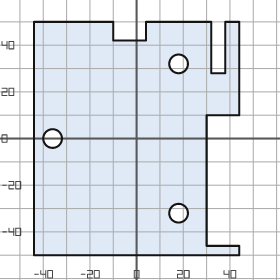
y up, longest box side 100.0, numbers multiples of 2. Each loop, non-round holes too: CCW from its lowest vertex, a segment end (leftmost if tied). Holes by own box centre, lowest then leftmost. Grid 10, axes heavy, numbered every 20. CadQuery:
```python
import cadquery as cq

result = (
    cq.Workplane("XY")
    .moveTo(-44.0, -50.0)
    .lineTo(44.0, -50.0)
    .lineTo(44.0, -46.0)
    .lineTo(30.0, -46.0)
    .lineTo(30.0, 10.0)
    .lineTo(44.0, 10.0)
    .lineTo(44.0, 50.0)
    .lineTo(38.0, 50.0)
    .lineTo(38.0, 28.0)
    .lineTo(32.0, 28.0)
    .lineTo(32.0, 50.0)
    .lineTo(4.0, 50.0)
    .lineTo(4.0, 42.0)
    .lineTo(-10.0, 42.0)
    .lineTo(-10.0, 50.0)
    .lineTo(-44.0, 50.0)
    .close()
    .moveTo(18.0, -32.0)
    .circle(4.0)
    .moveTo(-36.0, 0.0)
    .circle(4.0)
    .moveTo(18.0, 32.0)
    .circle(4.0)
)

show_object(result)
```